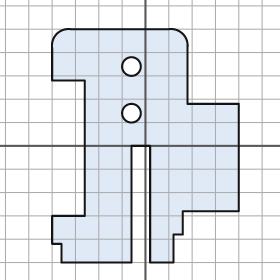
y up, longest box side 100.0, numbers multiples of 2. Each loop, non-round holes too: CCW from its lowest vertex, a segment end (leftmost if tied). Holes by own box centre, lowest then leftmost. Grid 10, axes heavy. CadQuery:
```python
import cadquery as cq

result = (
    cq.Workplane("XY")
    .moveTo(-36.0, -50.0)
    .lineTo(-6.0, -50.0)
    .lineTo(-6.0, 0.0)
    .lineTo(2.0, 0.0)
    .lineTo(2.0, -50.0)
    .lineTo(12.0, -50.0)
    .lineTo(12.0, -38.0)
    .lineTo(16.0, -38.0)
    .lineTo(16.0, -28.0)
    .lineTo(40.0, -28.0)
    .lineTo(40.0, 18.0)
    .lineTo(18.0, 18.0)
    .lineTo(18.0, 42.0)
    .threePointArc((16.0, 48.0), (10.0, 50.0))
    .lineTo(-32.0, 50.0)
    .threePointArc((-38.0, 48.0), (-40.0, 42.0))
    .lineTo(-40.0, 28.0)
    .lineTo(-26.0, 28.0)
    .lineTo(-26.0, -30.0)
    .lineTo(-40.0, -30.0)
    .lineTo(-40.0, -42.0)
    .lineTo(-36.0, -42.0)
    .close()
    .moveTo(-6.0, 14.0)
    .circle(4.0)
    .moveTo(-6.0, 34.0)
    .circle(4.0)
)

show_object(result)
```